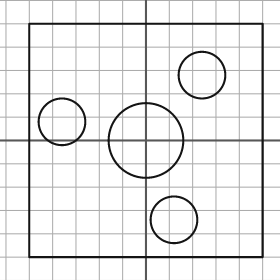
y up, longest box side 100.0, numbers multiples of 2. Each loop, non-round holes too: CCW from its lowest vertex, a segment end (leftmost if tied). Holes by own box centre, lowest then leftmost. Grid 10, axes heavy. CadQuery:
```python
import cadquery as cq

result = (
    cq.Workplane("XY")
    .moveTo(-50.0, -50.0)
    .lineTo(50.0, -50.0)
    .lineTo(50.0, 50.0)
    .lineTo(-50.0, 50.0)
    .close()
    .moveTo(12.0, -34.0)
    .circle(10.0)
    .moveTo(0.0, 0.0)
    .circle(16.0)
    .moveTo(-36.0, 8.0)
    .circle(10.0)
    .moveTo(24.0, 28.0)
    .circle(10.0)
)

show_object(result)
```